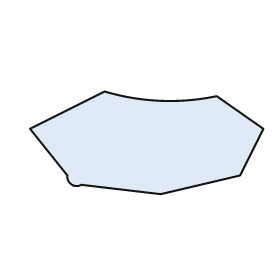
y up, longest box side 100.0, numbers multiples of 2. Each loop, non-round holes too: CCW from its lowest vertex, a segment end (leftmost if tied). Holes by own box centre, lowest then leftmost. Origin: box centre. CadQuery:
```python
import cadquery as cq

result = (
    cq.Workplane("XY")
    .moveTo(6.0, -22.0)
    .lineTo(40.0, -14.0)
    .lineTo(50.0, 6.0)
    .lineTo(30.0, 20.0)
    .threePointArc((6.0, 18.0), (-18.0, 22.0))
    .lineTo(-50.0, 6.0)
    .lineTo(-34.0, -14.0)
    .threePointArc((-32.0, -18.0), (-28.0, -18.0))
    .close()
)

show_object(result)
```